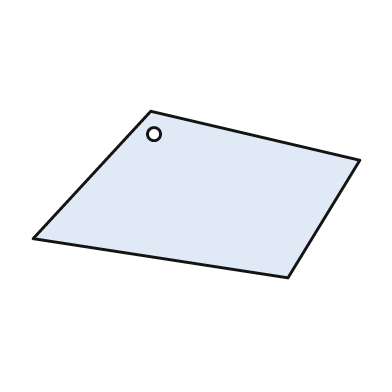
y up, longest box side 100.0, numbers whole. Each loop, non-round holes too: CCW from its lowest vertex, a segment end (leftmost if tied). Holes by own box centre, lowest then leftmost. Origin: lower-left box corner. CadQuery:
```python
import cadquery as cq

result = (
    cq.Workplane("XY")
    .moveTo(78.0, 0.0)
    .lineTo(100.0, 36.0)
    .lineTo(36.0, 51.0)
    .lineTo(0.0, 12.0)
    .close()
    .moveTo(37.0, 44.0)
    .circle(2.0)
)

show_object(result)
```